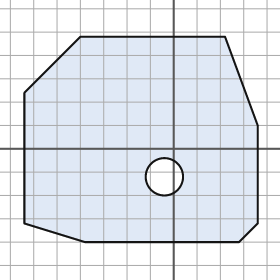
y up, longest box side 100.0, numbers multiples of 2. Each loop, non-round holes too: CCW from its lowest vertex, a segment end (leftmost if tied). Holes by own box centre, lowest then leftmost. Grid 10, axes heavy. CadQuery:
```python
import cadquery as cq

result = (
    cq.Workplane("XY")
    .moveTo(-38.0, -40.0)
    .lineTo(28.0, -40.0)
    .lineTo(36.0, -32.0)
    .lineTo(36.0, 10.0)
    .lineTo(22.0, 48.0)
    .lineTo(-40.0, 48.0)
    .lineTo(-64.0, 24.0)
    .lineTo(-64.0, -32.0)
    .close()
    .moveTo(-4.0, -12.0)
    .circle(8.0)
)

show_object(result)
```